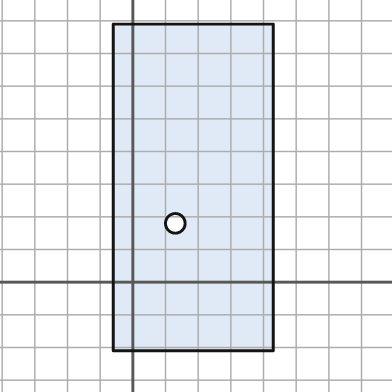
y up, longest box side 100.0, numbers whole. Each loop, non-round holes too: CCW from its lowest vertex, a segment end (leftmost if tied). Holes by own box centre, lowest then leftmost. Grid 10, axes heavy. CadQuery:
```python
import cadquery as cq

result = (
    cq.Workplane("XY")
    .moveTo(-6.0, -21.0)
    .lineTo(43.0, -21.0)
    .lineTo(43.0, 79.0)
    .lineTo(-6.0, 79.0)
    .close()
    .moveTo(13.0, 18.0)
    .circle(3.0)
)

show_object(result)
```